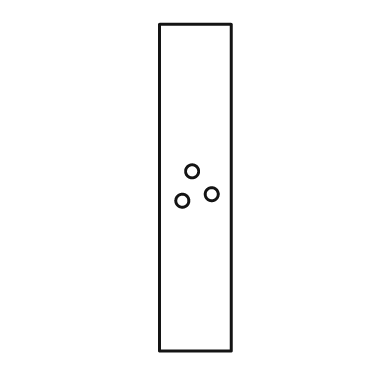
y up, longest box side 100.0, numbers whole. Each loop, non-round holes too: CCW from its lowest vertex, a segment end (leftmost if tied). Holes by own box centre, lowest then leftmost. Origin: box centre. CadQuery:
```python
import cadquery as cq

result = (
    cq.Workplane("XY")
    .moveTo(-11.0, -50.0)
    .lineTo(11.0, -50.0)
    .lineTo(11.0, 50.0)
    .lineTo(-11.0, 50.0)
    .close()
    .moveTo(-4.0, -4.0)
    .circle(2.0)
    .moveTo(5.0, -2.0)
    .circle(2.0)
    .moveTo(-1.0, 5.0)
    .circle(2.0)
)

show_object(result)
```